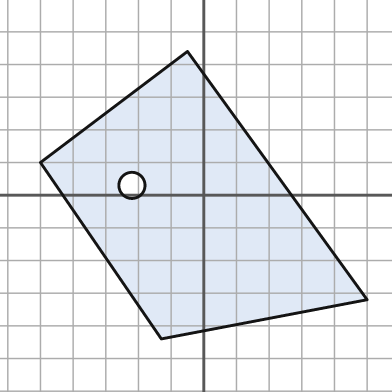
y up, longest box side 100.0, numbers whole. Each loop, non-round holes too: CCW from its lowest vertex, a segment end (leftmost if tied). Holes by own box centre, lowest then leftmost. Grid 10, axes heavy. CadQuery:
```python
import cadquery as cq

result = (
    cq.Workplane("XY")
    .moveTo(-13.0, -44.0)
    .lineTo(50.0, -32.0)
    .lineTo(-5.0, 44.0)
    .lineTo(-50.0, 10.0)
    .close()
    .moveTo(-22.0, 3.0)
    .circle(4.0)
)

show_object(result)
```